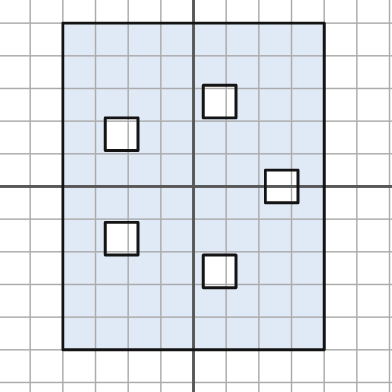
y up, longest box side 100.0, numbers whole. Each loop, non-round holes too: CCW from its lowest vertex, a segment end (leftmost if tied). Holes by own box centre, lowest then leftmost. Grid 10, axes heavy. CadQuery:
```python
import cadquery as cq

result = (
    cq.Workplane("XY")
    .moveTo(-40.0, -50.0)
    .lineTo(40.0, -50.0)
    .lineTo(40.0, 50.0)
    .lineTo(-40.0, 50.0)
    .close()
    .moveTo(3.0, -31.0)
    .lineTo(13.0, -31.0)
    .lineTo(13.0, -21.0)
    .lineTo(3.0, -21.0)
    .close()
    .moveTo(-27.0, -21.0)
    .lineTo(-17.0, -21.0)
    .lineTo(-17.0, -11.0)
    .lineTo(-27.0, -11.0)
    .close()
    .moveTo(22.0, -5.0)
    .lineTo(32.0, -5.0)
    .lineTo(32.0, 5.0)
    .lineTo(22.0, 5.0)
    .close()
    .moveTo(-27.0, 11.0)
    .lineTo(-17.0, 11.0)
    .lineTo(-17.0, 21.0)
    .lineTo(-27.0, 21.0)
    .close()
    .moveTo(3.0, 21.0)
    .lineTo(13.0, 21.0)
    .lineTo(13.0, 31.0)
    .lineTo(3.0, 31.0)
    .close()
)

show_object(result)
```